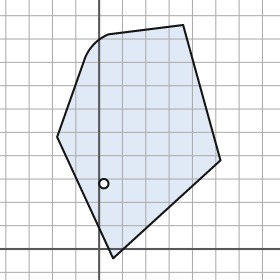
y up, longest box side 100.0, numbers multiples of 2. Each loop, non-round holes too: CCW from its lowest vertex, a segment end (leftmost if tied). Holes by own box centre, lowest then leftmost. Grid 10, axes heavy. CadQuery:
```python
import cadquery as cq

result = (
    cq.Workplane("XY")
    .moveTo(6.0, -4.0)
    .lineTo(52.0, 38.0)
    .lineTo(36.0, 96.0)
    .lineTo(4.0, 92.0)
    .threePointArc((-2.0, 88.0), (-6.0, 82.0))
    .lineTo(-18.0, 48.0)
    .close()
    .moveTo(2.0, 28.0)
    .circle(2.0)
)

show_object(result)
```